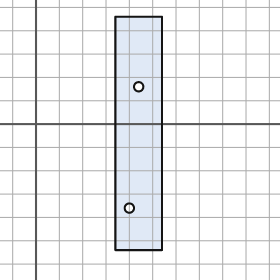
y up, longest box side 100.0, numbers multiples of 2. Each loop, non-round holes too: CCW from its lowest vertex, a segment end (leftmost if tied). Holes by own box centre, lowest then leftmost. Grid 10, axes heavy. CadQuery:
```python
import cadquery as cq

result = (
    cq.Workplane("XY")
    .moveTo(34.0, -54.0)
    .lineTo(54.0, -54.0)
    .lineTo(54.0, 46.0)
    .lineTo(34.0, 46.0)
    .close()
    .moveTo(40.0, -36.0)
    .circle(2.0)
    .moveTo(44.0, 16.0)
    .circle(2.0)
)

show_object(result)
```